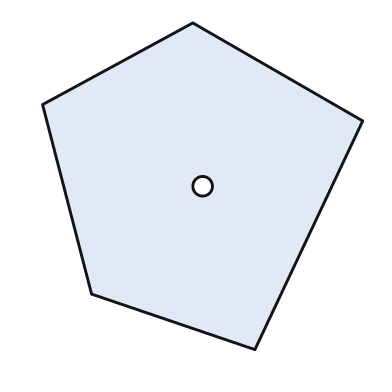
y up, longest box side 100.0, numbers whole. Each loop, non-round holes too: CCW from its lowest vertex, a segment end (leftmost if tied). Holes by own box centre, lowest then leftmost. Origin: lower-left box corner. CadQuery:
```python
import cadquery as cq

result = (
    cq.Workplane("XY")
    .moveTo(65.0, 0.0)
    .lineTo(98.0, 70.0)
    .lineTo(46.0, 100.0)
    .lineTo(0.0, 75.0)
    .lineTo(15.0, 17.0)
    .close()
    .moveTo(49.0, 50.0)
    .circle(3.0)
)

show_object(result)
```